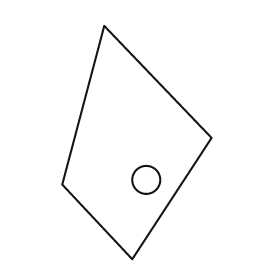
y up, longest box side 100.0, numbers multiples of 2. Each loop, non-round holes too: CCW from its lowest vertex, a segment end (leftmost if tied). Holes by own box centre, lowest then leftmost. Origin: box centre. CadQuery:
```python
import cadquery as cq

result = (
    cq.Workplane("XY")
    .moveTo(-2.0, -50.0)
    .lineTo(32.0, 2.0)
    .lineTo(-14.0, 50.0)
    .lineTo(-32.0, -18.0)
    .close()
    .moveTo(4.0, -16.0)
    .circle(6.0)
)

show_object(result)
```